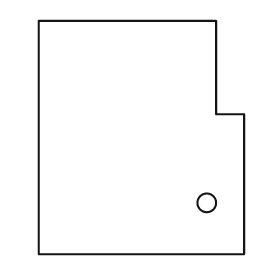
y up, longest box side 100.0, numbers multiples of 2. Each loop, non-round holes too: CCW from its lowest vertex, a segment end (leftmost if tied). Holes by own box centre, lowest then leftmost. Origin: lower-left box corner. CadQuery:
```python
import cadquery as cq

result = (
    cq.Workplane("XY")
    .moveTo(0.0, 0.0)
    .lineTo(88.0, 0.0)
    .lineTo(88.0, 60.0)
    .lineTo(76.0, 60.0)
    .lineTo(76.0, 100.0)
    .lineTo(0.0, 100.0)
    .close()
    .moveTo(72.0, 22.0)
    .circle(4.0)
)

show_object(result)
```